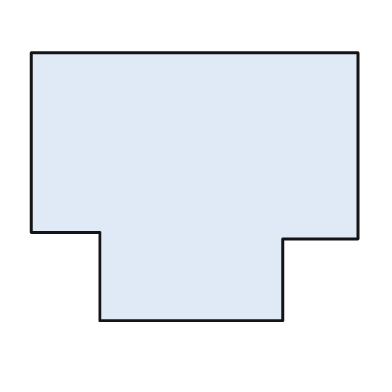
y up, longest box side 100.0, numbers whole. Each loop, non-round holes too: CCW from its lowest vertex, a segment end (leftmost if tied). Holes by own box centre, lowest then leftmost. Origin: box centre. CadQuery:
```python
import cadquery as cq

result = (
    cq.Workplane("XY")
    .moveTo(-29.0, -41.0)
    .lineTo(27.0, -41.0)
    .lineTo(27.0, -16.0)
    .lineTo(50.0, -16.0)
    .lineTo(50.0, 41.0)
    .lineTo(-50.0, 41.0)
    .lineTo(-50.0, -14.0)
    .lineTo(-29.0, -14.0)
    .close()
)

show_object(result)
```